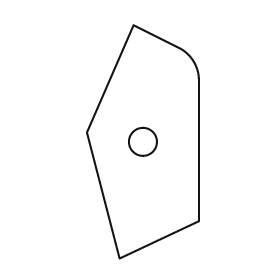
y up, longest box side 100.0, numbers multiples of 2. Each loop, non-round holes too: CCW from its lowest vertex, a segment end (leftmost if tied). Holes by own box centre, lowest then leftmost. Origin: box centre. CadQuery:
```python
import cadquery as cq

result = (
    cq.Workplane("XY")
    .moveTo(-10.0, -50.0)
    .lineTo(24.0, -34.0)
    .lineTo(24.0, 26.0)
    .threePointArc((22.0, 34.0), (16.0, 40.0))
    .lineTo(-4.0, 50.0)
    .lineTo(-24.0, 4.0)
    .close()
    .moveTo(0.0, 0.0)
    .circle(6.0)
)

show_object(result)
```